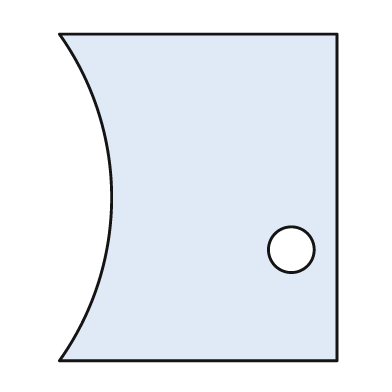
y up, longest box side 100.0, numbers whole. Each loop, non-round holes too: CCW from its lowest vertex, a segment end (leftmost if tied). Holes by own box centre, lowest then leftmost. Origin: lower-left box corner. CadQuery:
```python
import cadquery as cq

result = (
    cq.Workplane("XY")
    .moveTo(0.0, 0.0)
    .lineTo(85.0, 0.0)
    .lineTo(85.0, 100.0)
    .lineTo(0.0, 100.0)
    .threePointArc((16.0, 50.0), (0.0, 0.0))
    .close()
    .moveTo(71.0, 34.0)
    .circle(7.0)
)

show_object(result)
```